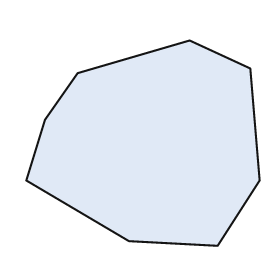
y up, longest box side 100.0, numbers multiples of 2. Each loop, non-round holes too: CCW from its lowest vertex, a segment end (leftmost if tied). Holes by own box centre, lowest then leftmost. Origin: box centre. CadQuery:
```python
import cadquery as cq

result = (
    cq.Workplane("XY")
    .moveTo(32.0, -44.0)
    .lineTo(50.0, -16.0)
    .lineTo(46.0, 32.0)
    .lineTo(20.0, 44.0)
    .lineTo(-28.0, 30.0)
    .lineTo(-42.0, 10.0)
    .lineTo(-50.0, -16.0)
    .lineTo(-6.0, -42.0)
    .close()
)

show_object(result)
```